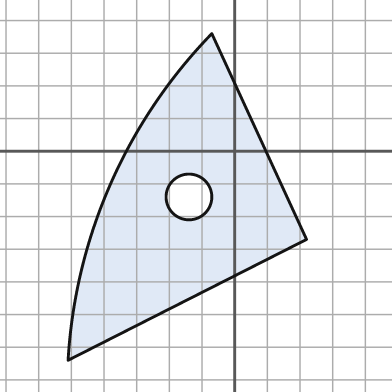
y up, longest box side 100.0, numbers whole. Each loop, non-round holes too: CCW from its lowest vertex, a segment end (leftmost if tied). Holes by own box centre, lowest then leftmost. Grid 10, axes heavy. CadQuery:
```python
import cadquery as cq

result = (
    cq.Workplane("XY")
    .moveTo(-51.0, -64.0)
    .lineTo(22.0, -27.0)
    .lineTo(-7.0, 36.0)
    .threePointArc((-38.0, -10.0), (-51.0, -64.0))
    .close()
    .moveTo(-14.0, -14.0)
    .circle(7.0)
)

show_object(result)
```